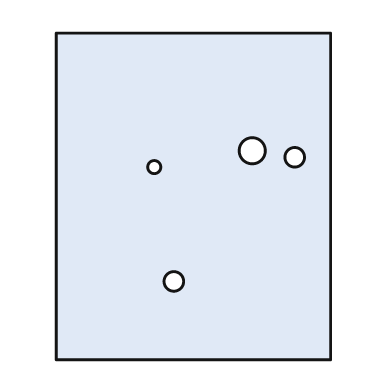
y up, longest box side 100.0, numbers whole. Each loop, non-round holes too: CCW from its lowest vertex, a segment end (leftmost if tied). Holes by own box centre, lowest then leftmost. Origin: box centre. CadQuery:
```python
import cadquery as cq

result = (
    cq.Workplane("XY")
    .moveTo(-42.0, -50.0)
    .lineTo(42.0, -50.0)
    .lineTo(42.0, 50.0)
    .lineTo(-42.0, 50.0)
    .close()
    .moveTo(-6.0, -26.0)
    .circle(3.0)
    .moveTo(-12.0, 9.0)
    .circle(2.0)
    .moveTo(31.0, 12.0)
    .circle(3.0)
    .moveTo(18.0, 14.0)
    .circle(4.0)
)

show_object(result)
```